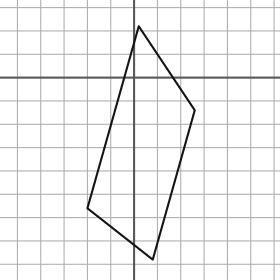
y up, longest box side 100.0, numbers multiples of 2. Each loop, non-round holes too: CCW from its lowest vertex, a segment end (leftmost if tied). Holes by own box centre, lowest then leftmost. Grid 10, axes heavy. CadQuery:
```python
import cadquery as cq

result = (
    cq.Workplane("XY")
    .moveTo(8.0, -78.0)
    .lineTo(26.0, -14.0)
    .lineTo(2.0, 22.0)
    .lineTo(-20.0, -56.0)
    .close()
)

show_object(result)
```